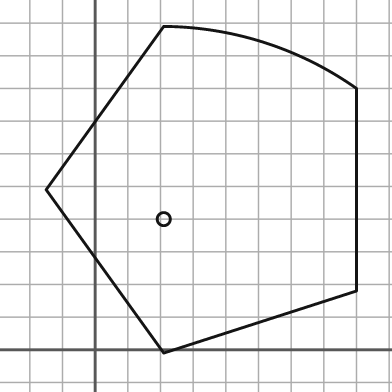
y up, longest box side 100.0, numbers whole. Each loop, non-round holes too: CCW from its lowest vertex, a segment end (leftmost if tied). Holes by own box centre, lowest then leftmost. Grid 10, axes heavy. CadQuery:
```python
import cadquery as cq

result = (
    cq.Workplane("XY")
    .moveTo(21.0, -1.0)
    .lineTo(80.0, 18.0)
    .lineTo(80.0, 80.0)
    .threePointArc((52.0, 94.0), (21.0, 99.0))
    .lineTo(-15.0, 49.0)
    .close()
    .moveTo(21.0, 40.0)
    .circle(2.0)
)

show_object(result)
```